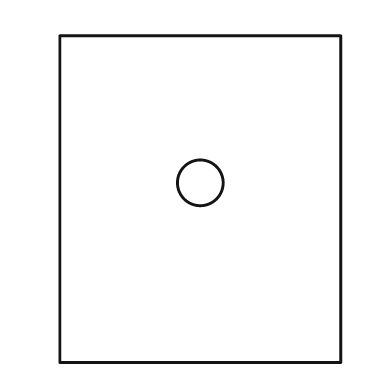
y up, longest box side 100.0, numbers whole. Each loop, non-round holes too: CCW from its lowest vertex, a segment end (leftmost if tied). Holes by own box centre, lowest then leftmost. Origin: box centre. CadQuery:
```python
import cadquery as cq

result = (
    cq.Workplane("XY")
    .moveTo(-43.0, -50.0)
    .lineTo(43.0, -50.0)
    .lineTo(43.0, 50.0)
    .lineTo(-43.0, 50.0)
    .close()
    .moveTo(0.0, 5.0)
    .circle(7.0)
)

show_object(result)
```